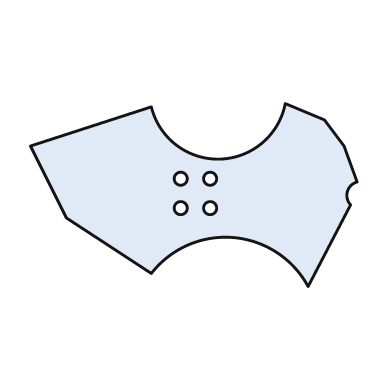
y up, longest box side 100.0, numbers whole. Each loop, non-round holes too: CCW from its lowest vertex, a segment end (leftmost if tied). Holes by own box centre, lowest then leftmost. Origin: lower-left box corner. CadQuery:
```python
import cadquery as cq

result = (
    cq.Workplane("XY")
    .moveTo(85.0, 0.0)
    .lineTo(98.0, 25.0)
    .threePointArc((97.0, 29.0), (100.0, 32.0))
    .lineTo(96.0, 43.0)
    .lineTo(90.0, 51.0)
    .lineTo(78.0, 56.0)
    .threePointArc((58.0, 39.0), (37.0, 55.0))
    .lineTo(0.0, 43.0)
    .lineTo(11.0, 21.0)
    .lineTo(37.0, 4.0)
    .threePointArc((62.0, 15.0), (85.0, 0.0))
    .close()
    .moveTo(46.0, 24.0)
    .circle(2.0)
    .moveTo(55.0, 24.0)
    .circle(2.0)
    .moveTo(46.0, 33.0)
    .circle(2.0)
    .moveTo(55.0, 33.0)
    .circle(2.0)
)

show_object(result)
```